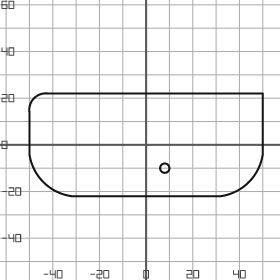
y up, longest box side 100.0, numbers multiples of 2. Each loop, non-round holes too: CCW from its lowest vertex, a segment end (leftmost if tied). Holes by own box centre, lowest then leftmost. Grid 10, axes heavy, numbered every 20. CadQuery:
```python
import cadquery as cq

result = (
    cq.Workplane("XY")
    .moveTo(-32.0, -22.0)
    .lineTo(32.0, -22.0)
    .threePointArc((44.0, -16.0), (50.0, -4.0))
    .lineTo(50.0, 22.0)
    .lineTo(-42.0, 22.0)
    .threePointArc((-48.0, 20.0), (-50.0, 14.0))
    .lineTo(-50.0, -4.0)
    .threePointArc((-44.0, -16.0), (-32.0, -22.0))
    .close()
    .moveTo(8.0, -10.0)
    .circle(2.0)
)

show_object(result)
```